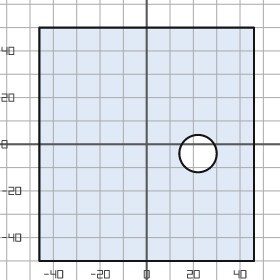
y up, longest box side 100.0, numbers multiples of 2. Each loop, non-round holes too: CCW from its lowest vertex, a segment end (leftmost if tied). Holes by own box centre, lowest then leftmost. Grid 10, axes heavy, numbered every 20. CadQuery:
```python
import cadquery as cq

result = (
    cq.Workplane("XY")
    .moveTo(-46.0, -50.0)
    .lineTo(46.0, -50.0)
    .lineTo(46.0, 50.0)
    .lineTo(-46.0, 50.0)
    .close()
    .moveTo(22.0, -4.0)
    .circle(8.0)
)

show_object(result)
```